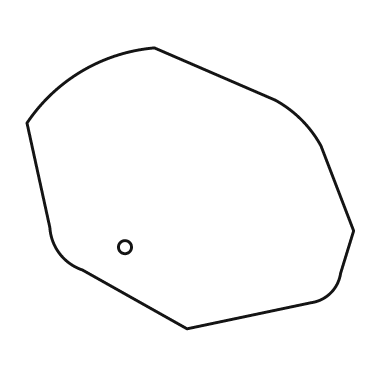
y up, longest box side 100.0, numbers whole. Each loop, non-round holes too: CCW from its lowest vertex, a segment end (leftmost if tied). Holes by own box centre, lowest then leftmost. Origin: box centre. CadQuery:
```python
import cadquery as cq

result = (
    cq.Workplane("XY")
    .moveTo(-1.0, -43.0)
    .lineTo(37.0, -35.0)
    .threePointArc((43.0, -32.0), (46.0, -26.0))
    .lineTo(50.0, -13.0)
    .lineTo(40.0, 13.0)
    .threePointArc((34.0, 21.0), (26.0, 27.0))
    .lineTo(-11.0, 43.0)
    .threePointArc((-33.0, 36.0), (-50.0, 20.0))
    .lineTo(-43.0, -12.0)
    .threePointArc((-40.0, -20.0), (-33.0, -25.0))
    .close()
    .moveTo(-20.0, -18.0)
    .circle(2.0)
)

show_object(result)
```